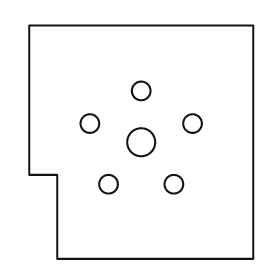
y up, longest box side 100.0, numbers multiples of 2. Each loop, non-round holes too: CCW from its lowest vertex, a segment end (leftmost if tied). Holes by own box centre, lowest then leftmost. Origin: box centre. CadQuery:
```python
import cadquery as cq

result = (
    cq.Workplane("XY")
    .moveTo(-36.0, -50.0)
    .lineTo(48.0, -50.0)
    .lineTo(48.0, 50.0)
    .lineTo(-48.0, 50.0)
    .lineTo(-48.0, -14.0)
    .lineTo(-36.0, -14.0)
    .close()
    .moveTo(-14.0, -18.0)
    .circle(4.0)
    .moveTo(14.0, -18.0)
    .circle(4.0)
    .moveTo(0.0, 0.0)
    .circle(6.0)
    .moveTo(-22.0, 8.0)
    .circle(4.0)
    .moveTo(22.0, 8.0)
    .circle(4.0)
    .moveTo(0.0, 22.0)
    .circle(4.0)
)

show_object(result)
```